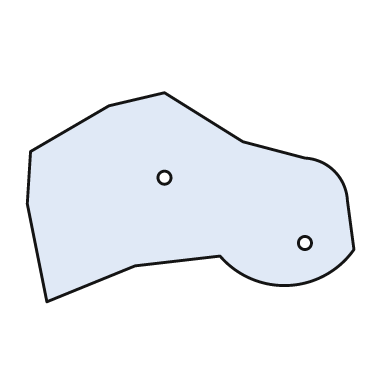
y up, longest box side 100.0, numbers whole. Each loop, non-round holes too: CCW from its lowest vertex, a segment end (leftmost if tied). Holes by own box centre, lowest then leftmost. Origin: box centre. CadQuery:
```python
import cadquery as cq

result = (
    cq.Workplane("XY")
    .moveTo(-44.0, -32.0)
    .lineTo(-17.0, -21.0)
    .lineTo(9.0, -18.0)
    .threePointArc((30.0, -27.0), (50.0, -16.0))
    .lineTo(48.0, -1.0)
    .threePointArc((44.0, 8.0), (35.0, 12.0))
    .lineTo(16.0, 17.0)
    .lineTo(-8.0, 32.0)
    .lineTo(-25.0, 28.0)
    .lineTo(-49.0, 14.0)
    .lineTo(-50.0, -2.0)
    .close()
    .moveTo(35.0, -14.0)
    .circle(2.0)
    .moveTo(-8.0, 6.0)
    .circle(2.0)
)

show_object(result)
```